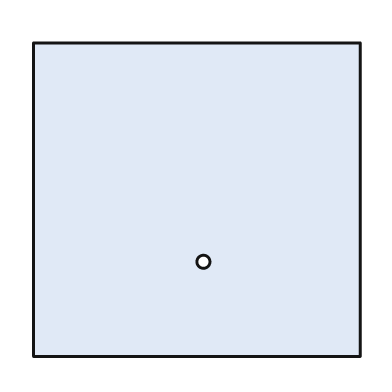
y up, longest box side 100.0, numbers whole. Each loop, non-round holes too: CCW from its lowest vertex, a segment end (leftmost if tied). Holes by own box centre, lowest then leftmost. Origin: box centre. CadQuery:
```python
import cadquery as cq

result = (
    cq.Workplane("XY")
    .moveTo(-50.0, -48.0)
    .lineTo(50.0, -48.0)
    .lineTo(50.0, 48.0)
    .lineTo(-50.0, 48.0)
    .close()
    .moveTo(2.0, -19.0)
    .circle(2.0)
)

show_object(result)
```